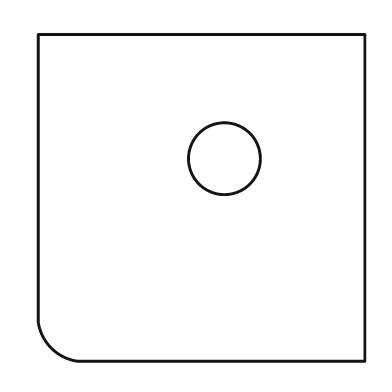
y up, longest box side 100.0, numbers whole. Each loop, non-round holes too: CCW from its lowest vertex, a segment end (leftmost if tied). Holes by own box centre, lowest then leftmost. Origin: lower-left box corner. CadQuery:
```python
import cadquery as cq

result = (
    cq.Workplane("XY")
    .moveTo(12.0, 0.0)
    .lineTo(100.0, 0.0)
    .lineTo(100.0, 100.0)
    .lineTo(0.0, 100.0)
    .lineTo(0.0, 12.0)
    .threePointArc((4.0, 4.0), (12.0, 0.0))
    .close()
    .moveTo(57.0, 62.0)
    .circle(11.0)
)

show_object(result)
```